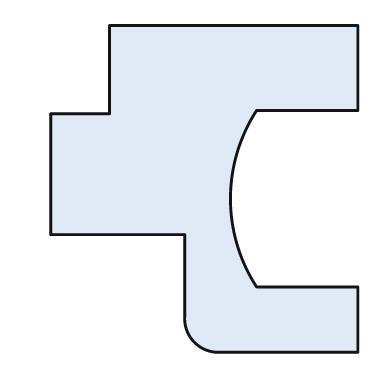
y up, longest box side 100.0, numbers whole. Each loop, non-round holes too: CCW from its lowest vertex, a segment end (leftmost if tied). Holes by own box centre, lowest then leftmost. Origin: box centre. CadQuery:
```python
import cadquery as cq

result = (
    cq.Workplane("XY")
    .moveTo(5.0, -50.0)
    .lineTo(47.0, -50.0)
    .lineTo(47.0, -30.0)
    .lineTo(16.0, -30.0)
    .threePointArc((8.0, -3.0), (16.0, 24.0))
    .lineTo(47.0, 24.0)
    .lineTo(47.0, 50.0)
    .lineTo(-29.0, 50.0)
    .lineTo(-29.0, 23.0)
    .lineTo(-47.0, 23.0)
    .lineTo(-47.0, -14.0)
    .lineTo(-6.0, -14.0)
    .lineTo(-6.0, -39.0)
    .threePointArc((-3.0, -47.0), (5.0, -50.0))
    .close()
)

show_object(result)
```